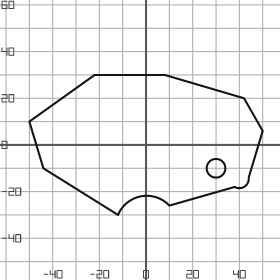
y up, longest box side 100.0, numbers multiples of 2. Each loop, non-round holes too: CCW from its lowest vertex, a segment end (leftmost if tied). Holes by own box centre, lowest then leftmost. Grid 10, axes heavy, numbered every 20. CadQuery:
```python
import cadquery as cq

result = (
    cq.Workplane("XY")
    .moveTo(-12.0, -30.0)
    .threePointArc((-2.0, -22.0), (10.0, -26.0))
    .lineTo(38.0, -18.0)
    .threePointArc((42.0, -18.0), (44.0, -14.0))
    .lineTo(50.0, 6.0)
    .lineTo(42.0, 20.0)
    .lineTo(8.0, 30.0)
    .lineTo(-22.0, 30.0)
    .lineTo(-50.0, 10.0)
    .lineTo(-44.0, -10.0)
    .close()
    .moveTo(30.0, -10.0)
    .circle(4.0)
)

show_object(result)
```